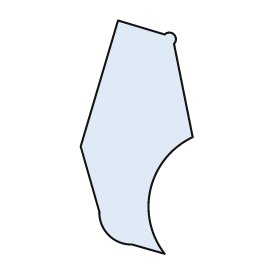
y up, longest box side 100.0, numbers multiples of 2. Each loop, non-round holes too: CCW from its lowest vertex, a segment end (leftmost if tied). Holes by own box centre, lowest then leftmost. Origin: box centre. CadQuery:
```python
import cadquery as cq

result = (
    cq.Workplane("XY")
    .moveTo(12.0, -50.0)
    .threePointArc((6.0, -22.0), (24.0, 0.0))
    .lineTo(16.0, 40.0)
    .threePointArc((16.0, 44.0), (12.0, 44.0))
    .lineTo(-8.0, 50.0)
    .lineTo(-24.0, -4.0)
    .lineTo(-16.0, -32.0)
    .threePointArc((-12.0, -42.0), (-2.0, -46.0))
    .close()
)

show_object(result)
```